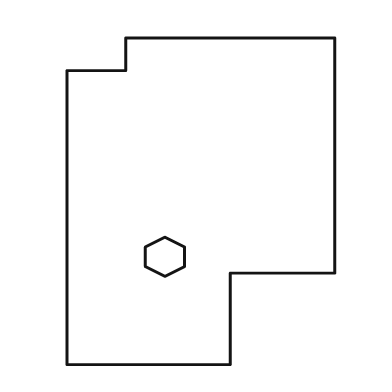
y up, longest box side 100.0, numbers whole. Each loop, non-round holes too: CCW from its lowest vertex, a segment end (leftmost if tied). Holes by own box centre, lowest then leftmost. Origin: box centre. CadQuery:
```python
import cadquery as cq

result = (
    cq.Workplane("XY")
    .moveTo(-41.0, -50.0)
    .lineTo(9.0, -50.0)
    .lineTo(9.0, -22.0)
    .lineTo(41.0, -22.0)
    .lineTo(41.0, 50.0)
    .lineTo(-23.0, 50.0)
    .lineTo(-23.0, 40.0)
    .lineTo(-41.0, 40.0)
    .close()
    .moveTo(-11.0, -23.0)
    .lineTo(-5.0, -20.0)
    .lineTo(-5.0, -14.0)
    .lineTo(-11.0, -11.0)
    .lineTo(-17.0, -14.0)
    .lineTo(-17.0, -20.0)
    .close()
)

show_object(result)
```